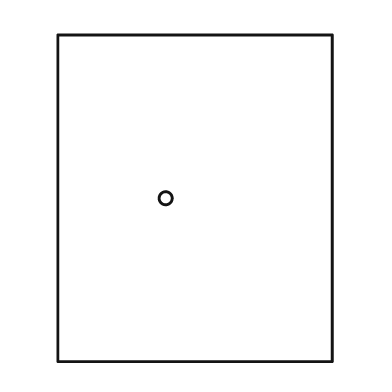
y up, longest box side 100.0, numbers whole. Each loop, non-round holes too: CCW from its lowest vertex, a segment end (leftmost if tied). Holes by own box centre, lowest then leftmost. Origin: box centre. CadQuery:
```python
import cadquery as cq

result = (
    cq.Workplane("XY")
    .moveTo(-42.0, -50.0)
    .lineTo(42.0, -50.0)
    .lineTo(42.0, 50.0)
    .lineTo(-42.0, 50.0)
    .close()
    .moveTo(-9.0, 0.0)
    .circle(2.0)
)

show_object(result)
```